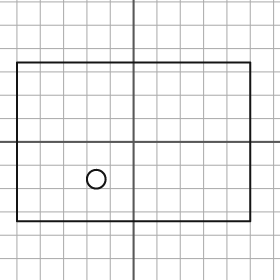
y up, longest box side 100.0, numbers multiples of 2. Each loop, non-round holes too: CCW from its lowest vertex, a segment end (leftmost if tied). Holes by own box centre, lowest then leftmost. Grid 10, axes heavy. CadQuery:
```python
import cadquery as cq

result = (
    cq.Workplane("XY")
    .moveTo(-50.0, -34.0)
    .lineTo(50.0, -34.0)
    .lineTo(50.0, 34.0)
    .lineTo(-50.0, 34.0)
    .close()
    .moveTo(-16.0, -16.0)
    .circle(4.0)
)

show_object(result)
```